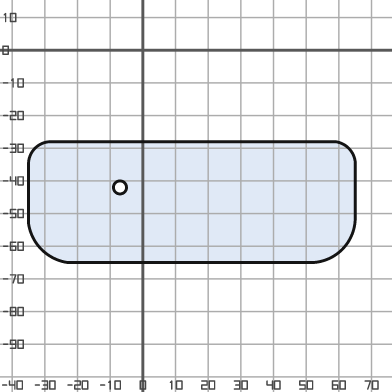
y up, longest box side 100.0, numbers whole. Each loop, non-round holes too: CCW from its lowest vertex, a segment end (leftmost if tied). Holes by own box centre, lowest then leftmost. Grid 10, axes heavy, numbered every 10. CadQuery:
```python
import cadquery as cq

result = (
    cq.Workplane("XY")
    .moveTo(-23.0, -65.0)
    .lineTo(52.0, -65.0)
    .threePointArc((61.0, -61.0), (65.0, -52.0))
    .lineTo(65.0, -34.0)
    .threePointArc((63.0, -30.0), (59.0, -28.0))
    .lineTo(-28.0, -28.0)
    .threePointArc((-33.0, -30.0), (-35.0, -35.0))
    .lineTo(-35.0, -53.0)
    .threePointArc((-31.0, -61.0), (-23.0, -65.0))
    .close()
    .moveTo(-7.0, -42.0)
    .circle(2.0)
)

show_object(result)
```